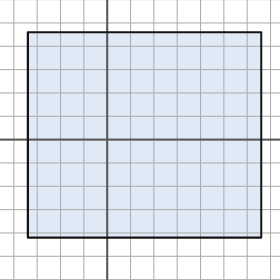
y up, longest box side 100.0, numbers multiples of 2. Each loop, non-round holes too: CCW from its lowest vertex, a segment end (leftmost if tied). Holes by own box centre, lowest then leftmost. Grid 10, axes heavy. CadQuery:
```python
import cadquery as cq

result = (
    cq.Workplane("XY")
    .moveTo(-34.0, -42.0)
    .lineTo(66.0, -42.0)
    .lineTo(66.0, 46.0)
    .lineTo(-34.0, 46.0)
    .close()
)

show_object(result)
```